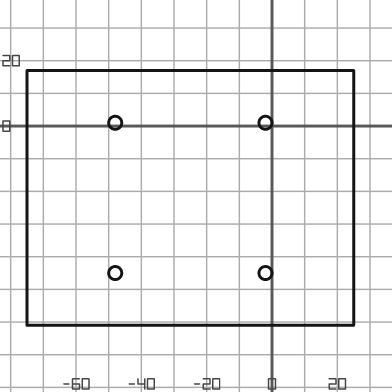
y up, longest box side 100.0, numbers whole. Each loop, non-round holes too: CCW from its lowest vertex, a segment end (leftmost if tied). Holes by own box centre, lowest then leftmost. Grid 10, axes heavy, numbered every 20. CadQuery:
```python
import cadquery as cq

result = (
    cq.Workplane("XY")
    .moveTo(-75.0, -61.0)
    .lineTo(25.0, -61.0)
    .lineTo(25.0, 17.0)
    .lineTo(-75.0, 17.0)
    .close()
    .moveTo(-48.0, -45.0)
    .circle(2.0)
    .moveTo(-2.0, -45.0)
    .circle(2.0)
    .moveTo(-48.0, 1.0)
    .circle(2.0)
    .moveTo(-2.0, 1.0)
    .circle(2.0)
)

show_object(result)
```